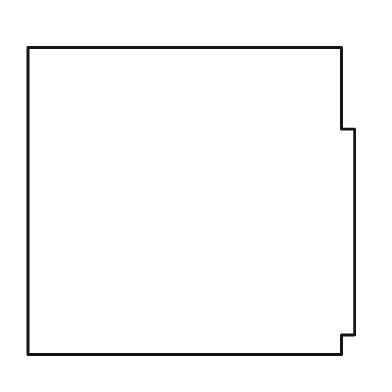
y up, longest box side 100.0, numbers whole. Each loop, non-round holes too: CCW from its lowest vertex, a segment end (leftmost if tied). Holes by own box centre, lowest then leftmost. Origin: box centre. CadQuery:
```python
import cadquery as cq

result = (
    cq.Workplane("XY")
    .moveTo(-50.0, -47.0)
    .lineTo(46.0, -47.0)
    .lineTo(46.0, -41.0)
    .lineTo(50.0, -41.0)
    .lineTo(50.0, 22.0)
    .lineTo(46.0, 22.0)
    .lineTo(46.0, 47.0)
    .lineTo(-50.0, 47.0)
    .close()
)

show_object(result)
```